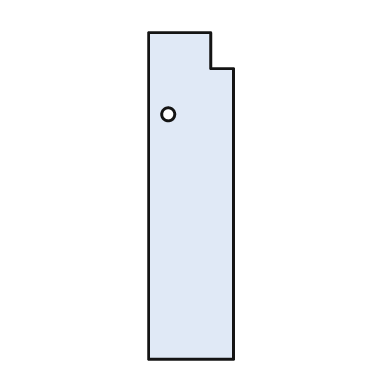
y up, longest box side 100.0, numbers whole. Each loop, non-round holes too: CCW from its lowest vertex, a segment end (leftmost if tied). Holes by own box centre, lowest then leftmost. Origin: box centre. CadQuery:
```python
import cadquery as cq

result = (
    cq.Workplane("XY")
    .moveTo(-13.0, -50.0)
    .lineTo(13.0, -50.0)
    .lineTo(13.0, 39.0)
    .lineTo(6.0, 39.0)
    .lineTo(6.0, 50.0)
    .lineTo(-13.0, 50.0)
    .close()
    .moveTo(-7.0, 25.0)
    .circle(2.0)
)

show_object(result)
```